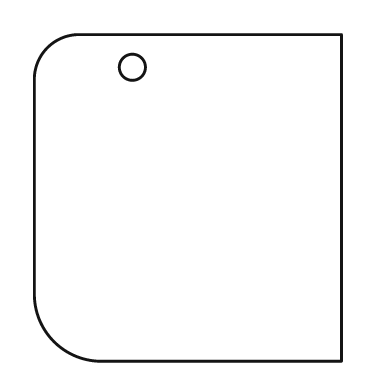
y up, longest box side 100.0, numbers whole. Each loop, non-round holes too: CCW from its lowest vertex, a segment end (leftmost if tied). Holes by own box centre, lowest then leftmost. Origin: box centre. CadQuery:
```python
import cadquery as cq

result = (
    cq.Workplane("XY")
    .moveTo(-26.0, -50.0)
    .lineTo(47.0, -50.0)
    .lineTo(47.0, 50.0)
    .lineTo(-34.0, 50.0)
    .threePointArc((-43.0, 46.0), (-47.0, 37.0))
    .lineTo(-47.0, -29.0)
    .threePointArc((-41.0, -44.0), (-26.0, -50.0))
    .close()
    .moveTo(-17.0, 40.0)
    .circle(4.0)
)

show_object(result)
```